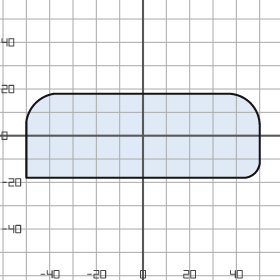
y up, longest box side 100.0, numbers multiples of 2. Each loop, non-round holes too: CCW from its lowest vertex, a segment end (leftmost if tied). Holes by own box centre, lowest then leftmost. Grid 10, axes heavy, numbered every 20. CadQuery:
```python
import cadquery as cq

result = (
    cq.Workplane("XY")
    .moveTo(-50.0, -18.0)
    .lineTo(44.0, -18.0)
    .threePointArc((48.0, -16.0), (50.0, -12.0))
    .lineTo(50.0, 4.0)
    .threePointArc((46.0, 14.0), (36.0, 18.0))
    .lineTo(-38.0, 18.0)
    .threePointArc((-46.0, 14.0), (-50.0, 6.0))
    .close()
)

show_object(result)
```